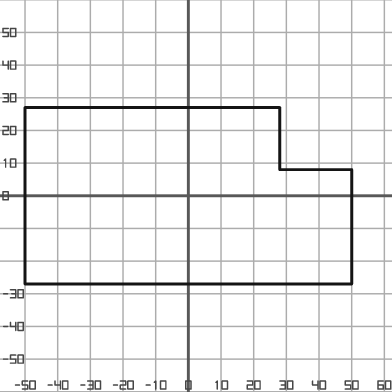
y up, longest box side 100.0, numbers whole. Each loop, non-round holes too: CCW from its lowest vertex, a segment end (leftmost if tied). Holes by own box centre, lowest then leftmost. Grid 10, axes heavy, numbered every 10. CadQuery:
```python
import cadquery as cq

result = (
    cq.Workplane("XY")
    .moveTo(-50.0, -27.0)
    .lineTo(50.0, -27.0)
    .lineTo(50.0, 8.0)
    .lineTo(28.0, 8.0)
    .lineTo(28.0, 27.0)
    .lineTo(-50.0, 27.0)
    .close()
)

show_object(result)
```